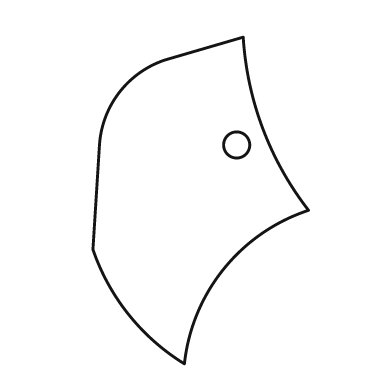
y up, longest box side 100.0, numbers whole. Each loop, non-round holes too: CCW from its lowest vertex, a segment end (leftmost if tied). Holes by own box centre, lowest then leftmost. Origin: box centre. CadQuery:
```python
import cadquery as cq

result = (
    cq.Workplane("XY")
    .moveTo(-5.0, -50.0)
    .threePointArc((7.0, -21.0), (33.0, -3.0))
    .threePointArc((19.0, 22.0), (13.0, 50.0))
    .lineTo(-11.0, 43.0)
    .threePointArc((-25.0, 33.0), (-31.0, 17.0))
    .lineTo(-33.0, -15.0)
    .threePointArc((-22.0, -35.0), (-5.0, -50.0))
    .close()
    .moveTo(11.0, 17.0)
    .circle(4.0)
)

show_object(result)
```